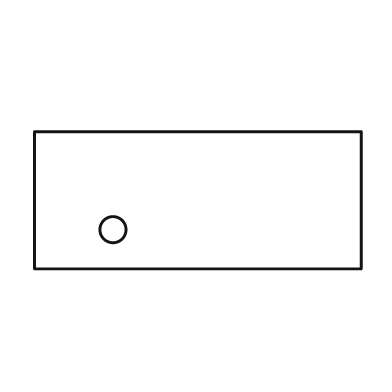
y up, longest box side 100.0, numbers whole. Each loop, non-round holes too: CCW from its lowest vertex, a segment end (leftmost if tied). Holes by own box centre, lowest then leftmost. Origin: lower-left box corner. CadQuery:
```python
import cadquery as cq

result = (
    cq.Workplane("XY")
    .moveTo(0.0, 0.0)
    .lineTo(100.0, 0.0)
    .lineTo(100.0, 42.0)
    .lineTo(0.0, 42.0)
    .close()
    .moveTo(24.0, 12.0)
    .circle(4.0)
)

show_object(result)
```